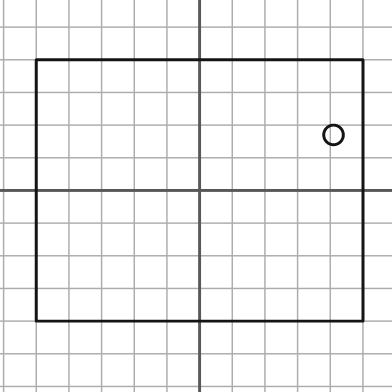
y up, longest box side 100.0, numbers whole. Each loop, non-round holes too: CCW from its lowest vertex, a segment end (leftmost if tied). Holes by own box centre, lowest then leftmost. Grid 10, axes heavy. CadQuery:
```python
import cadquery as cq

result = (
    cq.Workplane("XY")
    .moveTo(-50.0, -40.0)
    .lineTo(50.0, -40.0)
    .lineTo(50.0, 40.0)
    .lineTo(-50.0, 40.0)
    .close()
    .moveTo(41.0, 17.0)
    .circle(3.0)
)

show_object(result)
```